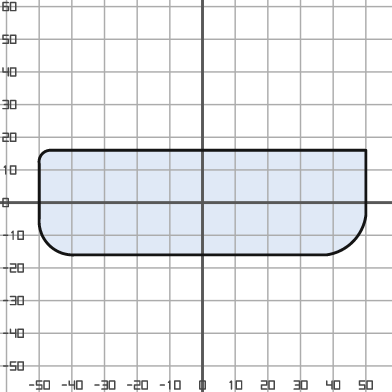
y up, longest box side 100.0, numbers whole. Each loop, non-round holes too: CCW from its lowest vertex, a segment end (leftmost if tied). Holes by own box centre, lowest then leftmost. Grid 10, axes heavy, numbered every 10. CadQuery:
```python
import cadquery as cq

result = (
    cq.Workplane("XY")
    .moveTo(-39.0, -16.0)
    .lineTo(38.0, -16.0)
    .threePointArc((46.0, -12.0), (50.0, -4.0))
    .lineTo(50.0, 16.0)
    .lineTo(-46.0, 16.0)
    .threePointArc((-49.0, 15.0), (-50.0, 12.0))
    .lineTo(-50.0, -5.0)
    .threePointArc((-47.0, -13.0), (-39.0, -16.0))
    .close()
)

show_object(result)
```